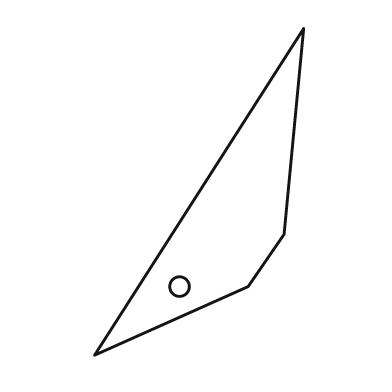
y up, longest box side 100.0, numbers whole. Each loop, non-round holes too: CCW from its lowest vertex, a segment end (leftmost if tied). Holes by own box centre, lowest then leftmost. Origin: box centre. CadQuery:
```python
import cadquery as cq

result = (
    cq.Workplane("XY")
    .moveTo(-32.0, -50.0)
    .lineTo(15.0, -29.0)
    .lineTo(26.0, -13.0)
    .lineTo(32.0, 50.0)
    .close()
    .moveTo(-6.0, -29.0)
    .circle(3.0)
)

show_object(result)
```